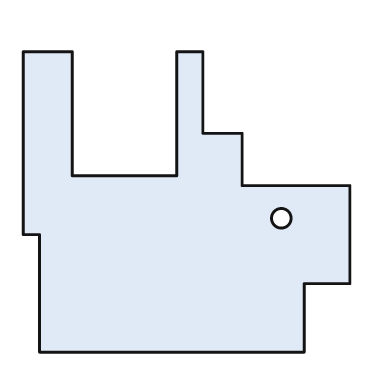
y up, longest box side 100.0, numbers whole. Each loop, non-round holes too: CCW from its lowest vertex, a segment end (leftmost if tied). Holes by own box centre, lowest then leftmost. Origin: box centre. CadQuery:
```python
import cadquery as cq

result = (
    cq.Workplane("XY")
    .moveTo(-45.0, -46.0)
    .lineTo(36.0, -46.0)
    .lineTo(36.0, -25.0)
    .lineTo(50.0, -25.0)
    .lineTo(50.0, 5.0)
    .lineTo(17.0, 5.0)
    .lineTo(17.0, 21.0)
    .lineTo(5.0, 21.0)
    .lineTo(5.0, 46.0)
    .lineTo(-3.0, 46.0)
    .lineTo(-3.0, 8.0)
    .lineTo(-35.0, 8.0)
    .lineTo(-35.0, 46.0)
    .lineTo(-50.0, 46.0)
    .lineTo(-50.0, -10.0)
    .lineTo(-45.0, -10.0)
    .close()
    .moveTo(29.0, -5.0)
    .circle(3.0)
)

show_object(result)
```